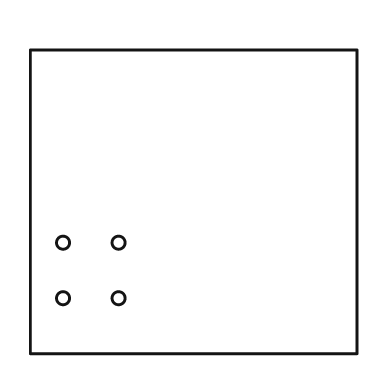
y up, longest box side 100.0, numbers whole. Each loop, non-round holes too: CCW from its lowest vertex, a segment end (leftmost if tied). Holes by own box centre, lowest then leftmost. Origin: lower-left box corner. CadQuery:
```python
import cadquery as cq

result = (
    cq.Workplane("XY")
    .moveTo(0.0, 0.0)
    .lineTo(100.0, 0.0)
    .lineTo(100.0, 93.0)
    .lineTo(0.0, 93.0)
    .close()
    .moveTo(10.0, 17.0)
    .circle(2.0)
    .moveTo(27.0, 17.0)
    .circle(2.0)
    .moveTo(10.0, 34.0)
    .circle(2.0)
    .moveTo(27.0, 34.0)
    .circle(2.0)
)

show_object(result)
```